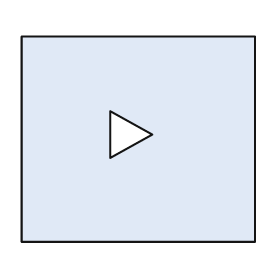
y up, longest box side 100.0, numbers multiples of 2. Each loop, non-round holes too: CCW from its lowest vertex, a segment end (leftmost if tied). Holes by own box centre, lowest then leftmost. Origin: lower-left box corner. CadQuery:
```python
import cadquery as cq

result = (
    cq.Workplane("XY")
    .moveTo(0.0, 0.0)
    .lineTo(100.0, 0.0)
    .lineTo(100.0, 88.0)
    .lineTo(0.0, 88.0)
    .close()
    .moveTo(38.0, 36.0)
    .lineTo(56.0, 46.0)
    .lineTo(38.0, 56.0)
    .close()
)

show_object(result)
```